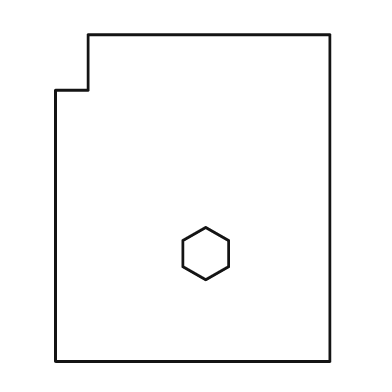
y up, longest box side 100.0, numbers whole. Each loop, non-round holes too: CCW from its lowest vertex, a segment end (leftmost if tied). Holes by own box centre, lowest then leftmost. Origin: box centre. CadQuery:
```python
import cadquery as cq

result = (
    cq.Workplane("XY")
    .moveTo(-42.0, -50.0)
    .lineTo(42.0, -50.0)
    .lineTo(42.0, 50.0)
    .lineTo(-32.0, 50.0)
    .lineTo(-32.0, 33.0)
    .lineTo(-42.0, 33.0)
    .close()
    .moveTo(4.0, -25.0)
    .lineTo(11.0, -21.0)
    .lineTo(11.0, -13.0)
    .lineTo(4.0, -9.0)
    .lineTo(-3.0, -13.0)
    .lineTo(-3.0, -21.0)
    .close()
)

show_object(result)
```